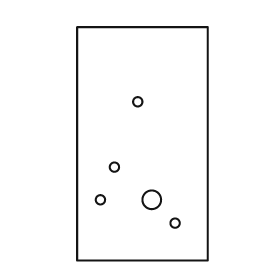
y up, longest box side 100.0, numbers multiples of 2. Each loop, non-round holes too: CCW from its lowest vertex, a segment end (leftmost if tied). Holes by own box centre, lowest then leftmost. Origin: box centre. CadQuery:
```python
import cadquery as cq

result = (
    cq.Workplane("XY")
    .moveTo(-28.0, -50.0)
    .lineTo(28.0, -50.0)
    .lineTo(28.0, 50.0)
    .lineTo(-28.0, 50.0)
    .close()
    .moveTo(14.0, -34.0)
    .circle(2.0)
    .moveTo(-18.0, -24.0)
    .circle(2.0)
    .moveTo(4.0, -24.0)
    .circle(4.0)
    .moveTo(-12.0, -10.0)
    .circle(2.0)
    .moveTo(-2.0, 18.0)
    .circle(2.0)
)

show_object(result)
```